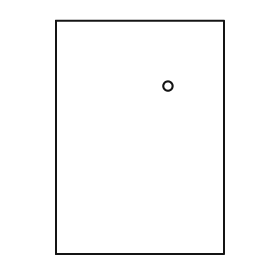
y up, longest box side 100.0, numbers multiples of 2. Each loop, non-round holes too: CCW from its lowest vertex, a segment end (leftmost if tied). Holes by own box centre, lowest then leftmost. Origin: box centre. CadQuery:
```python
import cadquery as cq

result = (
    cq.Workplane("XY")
    .moveTo(-36.0, -50.0)
    .lineTo(36.0, -50.0)
    .lineTo(36.0, 50.0)
    .lineTo(-36.0, 50.0)
    .close()
    .moveTo(12.0, 22.0)
    .circle(2.0)
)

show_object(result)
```